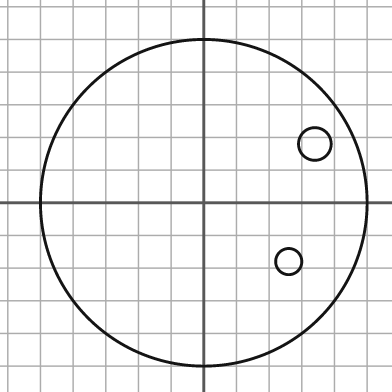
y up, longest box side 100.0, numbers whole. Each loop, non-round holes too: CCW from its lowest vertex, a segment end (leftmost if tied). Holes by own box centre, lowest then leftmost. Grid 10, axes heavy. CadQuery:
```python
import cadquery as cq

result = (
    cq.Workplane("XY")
    .moveTo(0.0, 0.0)
    .circle(50.0)
    .moveTo(26.0, -18.0)
    .circle(4.0)
    .moveTo(34.0, 18.0)
    .circle(5.0)
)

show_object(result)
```